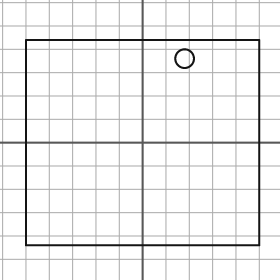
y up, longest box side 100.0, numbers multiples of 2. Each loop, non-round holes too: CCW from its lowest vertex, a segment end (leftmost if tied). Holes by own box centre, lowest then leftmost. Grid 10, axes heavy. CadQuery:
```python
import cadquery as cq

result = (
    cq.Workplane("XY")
    .moveTo(-50.0, -44.0)
    .lineTo(50.0, -44.0)
    .lineTo(50.0, 44.0)
    .lineTo(-50.0, 44.0)
    .close()
    .moveTo(18.0, 36.0)
    .circle(4.0)
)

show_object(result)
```